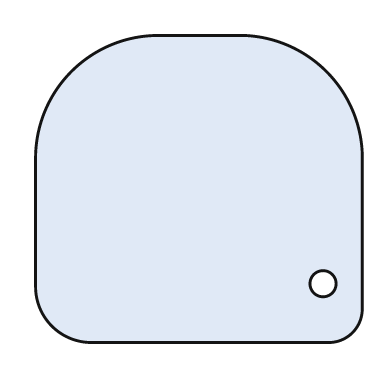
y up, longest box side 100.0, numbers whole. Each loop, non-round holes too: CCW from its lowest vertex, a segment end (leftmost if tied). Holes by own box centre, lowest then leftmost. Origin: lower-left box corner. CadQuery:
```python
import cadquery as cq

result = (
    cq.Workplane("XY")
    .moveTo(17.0, 0.0)
    .lineTo(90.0, 0.0)
    .threePointArc((97.0, 3.0), (100.0, 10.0))
    .lineTo(100.0, 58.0)
    .threePointArc((89.0, 83.0), (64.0, 94.0))
    .lineTo(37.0, 94.0)
    .threePointArc((11.0, 83.0), (0.0, 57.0))
    .lineTo(0.0, 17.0)
    .threePointArc((5.0, 5.0), (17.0, 0.0))
    .close()
    .moveTo(88.0, 18.0)
    .circle(4.0)
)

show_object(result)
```